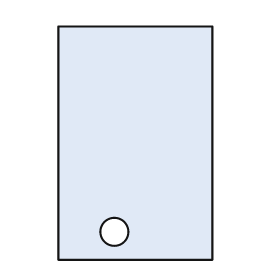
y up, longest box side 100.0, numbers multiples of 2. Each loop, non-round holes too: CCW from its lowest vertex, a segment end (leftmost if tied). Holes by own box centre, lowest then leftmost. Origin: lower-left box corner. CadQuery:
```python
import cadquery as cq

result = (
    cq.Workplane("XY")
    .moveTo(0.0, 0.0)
    .lineTo(66.0, 0.0)
    .lineTo(66.0, 100.0)
    .lineTo(0.0, 100.0)
    .close()
    .moveTo(24.0, 12.0)
    .circle(6.0)
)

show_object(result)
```